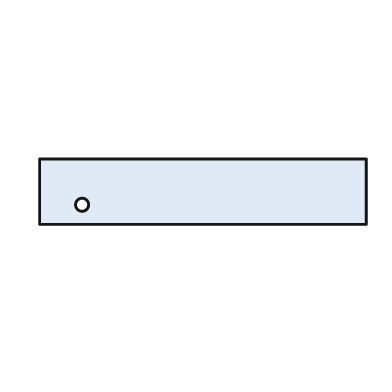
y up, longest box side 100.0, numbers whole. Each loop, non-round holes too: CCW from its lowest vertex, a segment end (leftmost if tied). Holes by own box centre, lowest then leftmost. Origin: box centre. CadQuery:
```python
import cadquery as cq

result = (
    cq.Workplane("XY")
    .moveTo(-50.0, -10.0)
    .lineTo(50.0, -10.0)
    .lineTo(50.0, 10.0)
    .lineTo(-50.0, 10.0)
    .close()
    .moveTo(-37.0, -4.0)
    .circle(2.0)
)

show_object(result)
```